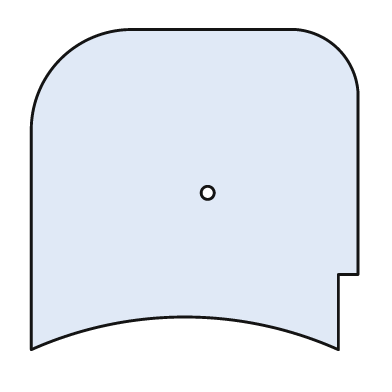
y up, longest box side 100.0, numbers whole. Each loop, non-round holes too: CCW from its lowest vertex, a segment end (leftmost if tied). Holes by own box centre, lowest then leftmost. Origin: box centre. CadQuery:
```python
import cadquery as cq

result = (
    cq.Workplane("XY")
    .moveTo(-50.0, -49.0)
    .threePointArc((-3.0, -39.0), (44.0, -49.0))
    .lineTo(44.0, -26.0)
    .lineTo(50.0, -26.0)
    .lineTo(50.0, 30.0)
    .threePointArc((44.0, 43.0), (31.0, 49.0))
    .lineTo(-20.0, 49.0)
    .threePointArc((-41.0, 40.0), (-50.0, 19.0))
    .close()
    .moveTo(4.0, -1.0)
    .circle(2.0)
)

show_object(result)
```